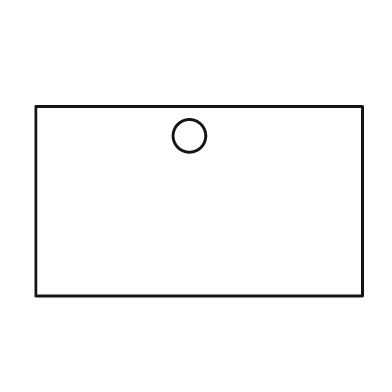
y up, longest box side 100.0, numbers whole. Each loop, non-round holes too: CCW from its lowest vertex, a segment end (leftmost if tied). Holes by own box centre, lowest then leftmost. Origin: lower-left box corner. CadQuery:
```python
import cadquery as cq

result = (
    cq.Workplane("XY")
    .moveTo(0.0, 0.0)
    .lineTo(100.0, 0.0)
    .lineTo(100.0, 58.0)
    .lineTo(0.0, 58.0)
    .close()
    .moveTo(47.0, 49.0)
    .circle(5.0)
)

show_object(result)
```